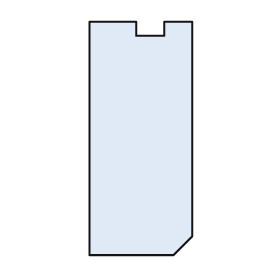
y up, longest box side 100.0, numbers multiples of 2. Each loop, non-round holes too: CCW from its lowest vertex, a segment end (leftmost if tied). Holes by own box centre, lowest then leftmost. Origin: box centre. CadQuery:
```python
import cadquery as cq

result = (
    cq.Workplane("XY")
    .moveTo(-22.0, -50.0)
    .lineTo(14.0, -50.0)
    .lineTo(22.0, -42.0)
    .lineTo(22.0, 50.0)
    .lineTo(10.0, 50.0)
    .lineTo(10.0, 44.0)
    .lineTo(-2.0, 44.0)
    .lineTo(-2.0, 50.0)
    .lineTo(-22.0, 50.0)
    .close()
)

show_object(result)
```